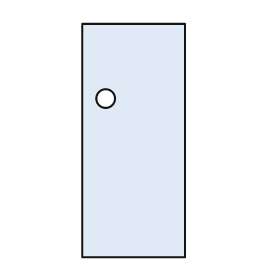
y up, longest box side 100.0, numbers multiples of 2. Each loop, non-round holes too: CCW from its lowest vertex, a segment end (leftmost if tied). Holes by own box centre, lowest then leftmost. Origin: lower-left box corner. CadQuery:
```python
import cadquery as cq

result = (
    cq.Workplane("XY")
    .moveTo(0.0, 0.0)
    .lineTo(44.0, 0.0)
    .lineTo(44.0, 100.0)
    .lineTo(0.0, 100.0)
    .close()
    .moveTo(10.0, 68.0)
    .circle(4.0)
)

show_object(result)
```